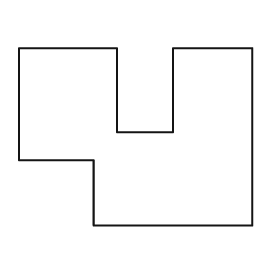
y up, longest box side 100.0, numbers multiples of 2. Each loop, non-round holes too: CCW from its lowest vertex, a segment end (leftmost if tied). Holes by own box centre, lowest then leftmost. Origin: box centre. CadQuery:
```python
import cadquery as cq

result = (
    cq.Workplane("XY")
    .moveTo(-18.0, -38.0)
    .lineTo(50.0, -38.0)
    .lineTo(50.0, 38.0)
    .lineTo(16.0, 38.0)
    .lineTo(16.0, 2.0)
    .lineTo(-8.0, 2.0)
    .lineTo(-8.0, 38.0)
    .lineTo(-50.0, 38.0)
    .lineTo(-50.0, -10.0)
    .lineTo(-18.0, -10.0)
    .close()
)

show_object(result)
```